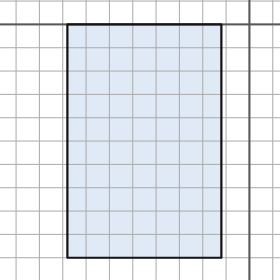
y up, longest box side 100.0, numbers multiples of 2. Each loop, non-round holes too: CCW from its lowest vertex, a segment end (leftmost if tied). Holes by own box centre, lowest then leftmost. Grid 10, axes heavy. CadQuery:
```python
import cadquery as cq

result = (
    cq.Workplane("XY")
    .moveTo(-78.0, -100.0)
    .lineTo(-12.0, -100.0)
    .lineTo(-12.0, 0.0)
    .lineTo(-78.0, 0.0)
    .close()
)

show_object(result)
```